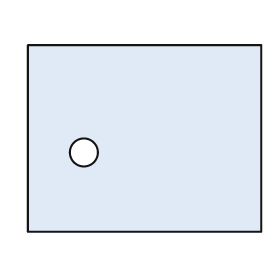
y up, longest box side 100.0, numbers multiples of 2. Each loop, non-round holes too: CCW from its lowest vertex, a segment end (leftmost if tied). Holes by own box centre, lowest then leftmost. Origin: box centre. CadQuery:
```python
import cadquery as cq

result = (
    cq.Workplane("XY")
    .moveTo(-50.0, -40.0)
    .lineTo(50.0, -40.0)
    .lineTo(50.0, 40.0)
    .lineTo(-50.0, 40.0)
    .close()
    .moveTo(-26.0, -6.0)
    .circle(6.0)
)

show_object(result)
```